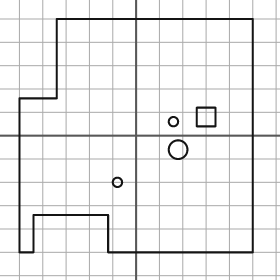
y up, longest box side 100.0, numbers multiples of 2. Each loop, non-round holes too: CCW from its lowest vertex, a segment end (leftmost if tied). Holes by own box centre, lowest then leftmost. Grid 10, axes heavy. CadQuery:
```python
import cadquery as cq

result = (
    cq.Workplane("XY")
    .moveTo(-50.0, -50.0)
    .lineTo(-44.0, -50.0)
    .lineTo(-44.0, -34.0)
    .lineTo(-12.0, -34.0)
    .lineTo(-12.0, -50.0)
    .lineTo(50.0, -50.0)
    .lineTo(50.0, 50.0)
    .lineTo(-34.0, 50.0)
    .lineTo(-34.0, 16.0)
    .lineTo(-50.0, 16.0)
    .close()
    .moveTo(-8.0, -20.0)
    .circle(2.0)
    .moveTo(18.0, -6.0)
    .circle(4.0)
    .moveTo(16.0, 6.0)
    .circle(2.0)
    .moveTo(26.0, 4.0)
    .lineTo(34.0, 4.0)
    .lineTo(34.0, 12.0)
    .lineTo(26.0, 12.0)
    .close()
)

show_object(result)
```